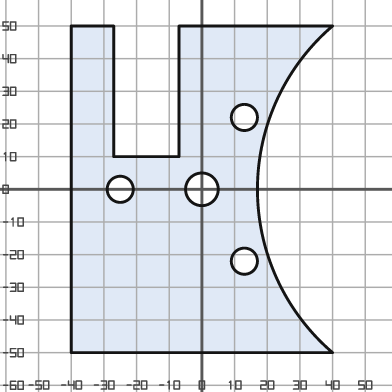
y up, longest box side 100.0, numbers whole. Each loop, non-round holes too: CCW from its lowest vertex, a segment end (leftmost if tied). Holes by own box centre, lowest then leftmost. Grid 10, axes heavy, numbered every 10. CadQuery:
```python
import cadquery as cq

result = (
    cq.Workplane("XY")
    .moveTo(-40.0, -50.0)
    .lineTo(40.0, -50.0)
    .threePointArc((17.0, 0.0), (40.0, 50.0))
    .lineTo(-7.0, 50.0)
    .lineTo(-7.0, 10.0)
    .lineTo(-27.0, 10.0)
    .lineTo(-27.0, 50.0)
    .lineTo(-40.0, 50.0)
    .close()
    .moveTo(13.0, -22.0)
    .circle(4.0)
    .moveTo(-25.0, 0.0)
    .circle(4.0)
    .moveTo(0.0, 0.0)
    .circle(5.0)
    .moveTo(13.0, 22.0)
    .circle(4.0)
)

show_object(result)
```